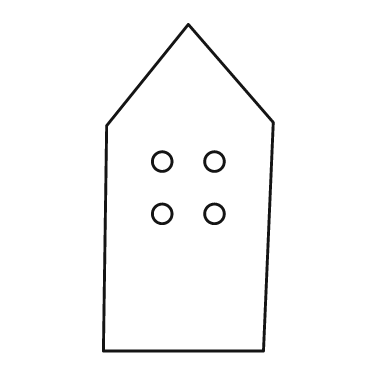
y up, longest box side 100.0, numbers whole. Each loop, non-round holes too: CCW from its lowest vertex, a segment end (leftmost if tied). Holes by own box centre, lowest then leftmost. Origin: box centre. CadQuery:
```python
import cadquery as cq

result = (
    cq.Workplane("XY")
    .moveTo(-26.0, -50.0)
    .lineTo(23.0, -50.0)
    .lineTo(26.0, 20.0)
    .lineTo(0.0, 50.0)
    .lineTo(-25.0, 19.0)
    .close()
    .moveTo(-8.0, -8.0)
    .circle(3.0)
    .moveTo(8.0, -8.0)
    .circle(3.0)
    .moveTo(-8.0, 8.0)
    .circle(3.0)
    .moveTo(8.0, 8.0)
    .circle(3.0)
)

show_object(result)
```